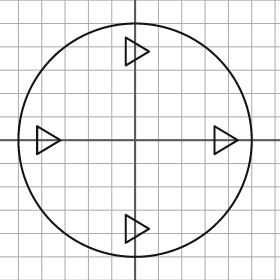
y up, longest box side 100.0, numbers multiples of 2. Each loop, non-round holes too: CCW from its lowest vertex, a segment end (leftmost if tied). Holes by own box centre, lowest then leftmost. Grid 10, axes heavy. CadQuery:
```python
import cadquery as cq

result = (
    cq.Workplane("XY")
    .moveTo(0.0, 0.0)
    .circle(50.0)
    .moveTo(-4.0, -44.0)
    .lineTo(6.0, -38.0)
    .lineTo(-4.0, -32.0)
    .close()
    .moveTo(-42.0, -6.0)
    .lineTo(-32.0, 0.0)
    .lineTo(-42.0, 6.0)
    .close()
    .moveTo(34.0, -6.0)
    .lineTo(44.0, 0.0)
    .lineTo(34.0, 6.0)
    .close()
    .moveTo(-4.0, 32.0)
    .lineTo(6.0, 38.0)
    .lineTo(-4.0, 44.0)
    .close()
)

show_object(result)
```